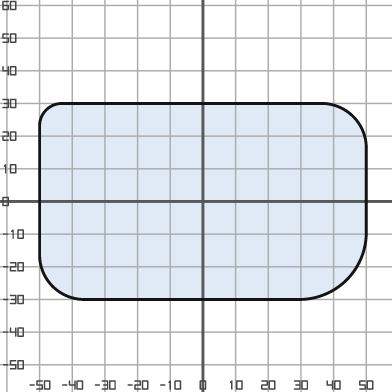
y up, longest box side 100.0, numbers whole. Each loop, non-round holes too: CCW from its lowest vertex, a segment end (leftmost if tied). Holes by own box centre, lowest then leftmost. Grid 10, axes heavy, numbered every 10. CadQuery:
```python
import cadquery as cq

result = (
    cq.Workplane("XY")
    .moveTo(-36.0, -30.0)
    .lineTo(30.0, -30.0)
    .threePointArc((44.0, -24.0), (50.0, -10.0))
    .lineTo(50.0, 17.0)
    .threePointArc((46.0, 26.0), (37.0, 30.0))
    .lineTo(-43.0, 30.0)
    .threePointArc((-48.0, 28.0), (-50.0, 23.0))
    .lineTo(-50.0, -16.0)
    .threePointArc((-46.0, -26.0), (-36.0, -30.0))
    .close()
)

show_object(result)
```